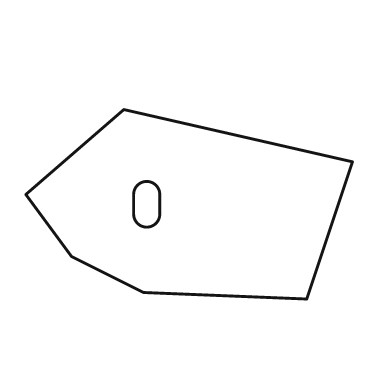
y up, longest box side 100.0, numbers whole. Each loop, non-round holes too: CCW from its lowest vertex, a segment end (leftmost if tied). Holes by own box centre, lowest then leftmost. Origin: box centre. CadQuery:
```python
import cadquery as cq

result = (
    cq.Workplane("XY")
    .moveTo(36.0, -29.0)
    .lineTo(50.0, 13.0)
    .lineTo(-20.0, 29.0)
    .lineTo(-50.0, 3.0)
    .lineTo(-36.0, -16.0)
    .lineTo(-14.0, -27.0)
    .close()
    .moveTo(-17.0, -3.0)
    .threePointArc((-13.0, -7.0), (-9.0, -3.0))
    .lineTo(-9.0, 3.0)
    .threePointArc((-13.0, 7.0), (-17.0, 3.0))
    .close()
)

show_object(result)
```